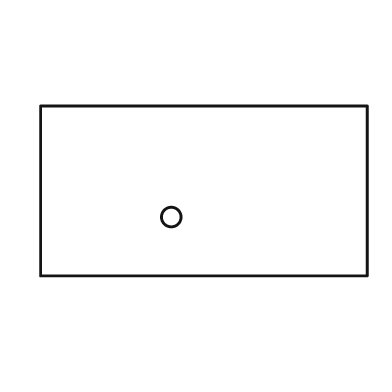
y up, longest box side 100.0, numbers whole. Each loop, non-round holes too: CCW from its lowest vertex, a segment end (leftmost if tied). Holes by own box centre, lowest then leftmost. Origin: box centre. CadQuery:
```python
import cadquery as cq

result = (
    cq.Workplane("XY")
    .moveTo(-50.0, -26.0)
    .lineTo(50.0, -26.0)
    .lineTo(50.0, 26.0)
    .lineTo(-50.0, 26.0)
    .close()
    .moveTo(-10.0, -8.0)
    .circle(3.0)
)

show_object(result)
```